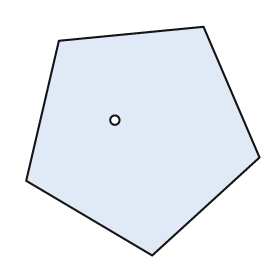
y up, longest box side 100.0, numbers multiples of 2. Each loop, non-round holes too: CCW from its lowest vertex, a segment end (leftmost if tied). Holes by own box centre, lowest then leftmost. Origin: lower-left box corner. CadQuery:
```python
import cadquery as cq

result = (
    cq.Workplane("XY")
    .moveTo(54.0, 0.0)
    .lineTo(100.0, 42.0)
    .lineTo(76.0, 98.0)
    .lineTo(14.0, 92.0)
    .lineTo(0.0, 32.0)
    .close()
    .moveTo(38.0, 58.0)
    .circle(2.0)
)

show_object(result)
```